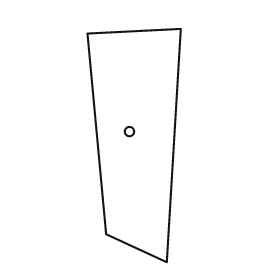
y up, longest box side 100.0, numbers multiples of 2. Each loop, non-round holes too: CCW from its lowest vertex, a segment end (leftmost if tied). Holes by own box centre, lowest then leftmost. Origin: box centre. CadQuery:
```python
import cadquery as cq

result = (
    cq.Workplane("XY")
    .moveTo(14.0, -50.0)
    .lineTo(20.0, 50.0)
    .lineTo(-20.0, 48.0)
    .lineTo(-12.0, -38.0)
    .close()
    .moveTo(-2.0, 6.0)
    .circle(2.0)
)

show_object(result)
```